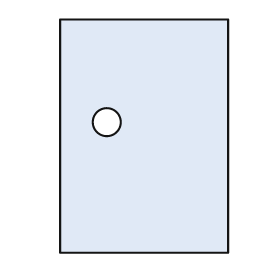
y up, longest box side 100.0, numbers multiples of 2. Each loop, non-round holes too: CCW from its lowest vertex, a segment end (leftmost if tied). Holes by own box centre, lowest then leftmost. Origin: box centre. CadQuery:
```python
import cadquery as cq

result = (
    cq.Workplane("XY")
    .moveTo(-36.0, -50.0)
    .lineTo(36.0, -50.0)
    .lineTo(36.0, 50.0)
    .lineTo(-36.0, 50.0)
    .close()
    .moveTo(-16.0, 6.0)
    .circle(6.0)
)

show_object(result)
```